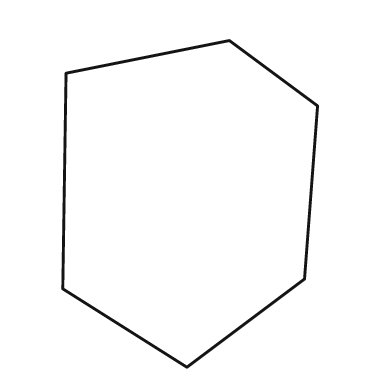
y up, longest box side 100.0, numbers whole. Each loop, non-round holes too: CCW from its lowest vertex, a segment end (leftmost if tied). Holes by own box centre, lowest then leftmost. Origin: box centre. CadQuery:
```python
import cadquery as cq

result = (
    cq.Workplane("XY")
    .moveTo(-1.0, -50.0)
    .lineTo(35.0, -23.0)
    .lineTo(39.0, 30.0)
    .lineTo(12.0, 50.0)
    .lineTo(-38.0, 40.0)
    .lineTo(-39.0, -26.0)
    .close()
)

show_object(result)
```